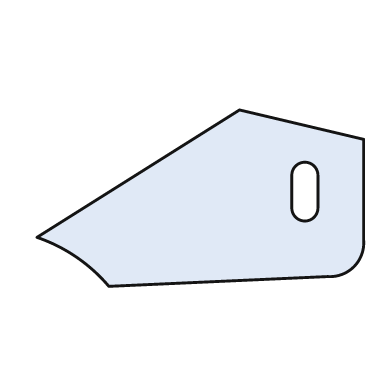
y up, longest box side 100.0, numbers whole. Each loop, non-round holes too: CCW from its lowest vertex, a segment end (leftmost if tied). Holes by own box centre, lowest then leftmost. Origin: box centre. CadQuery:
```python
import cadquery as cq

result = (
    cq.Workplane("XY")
    .moveTo(-28.0, -27.0)
    .lineTo(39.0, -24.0)
    .threePointArc((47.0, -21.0), (50.0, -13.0))
    .lineTo(50.0, 18.0)
    .lineTo(12.0, 27.0)
    .lineTo(-50.0, -12.0)
    .threePointArc((-38.0, -18.0), (-28.0, -27.0))
    .close()
    .moveTo(28.0, -3.0)
    .threePointArc((32.0, -7.0), (36.0, -3.0))
    .lineTo(36.0, 7.0)
    .threePointArc((32.0, 11.0), (28.0, 7.0))
    .close()
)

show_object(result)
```